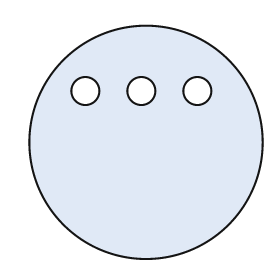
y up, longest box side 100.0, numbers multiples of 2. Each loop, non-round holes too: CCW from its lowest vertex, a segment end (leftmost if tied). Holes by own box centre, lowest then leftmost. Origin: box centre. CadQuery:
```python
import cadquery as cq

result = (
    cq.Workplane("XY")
    .moveTo(0.0, 0.0)
    .circle(50.0)
    .moveTo(-26.0, 22.0)
    .circle(6.0)
    .moveTo(-2.0, 22.0)
    .circle(6.0)
    .moveTo(22.0, 22.0)
    .circle(6.0)
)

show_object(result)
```